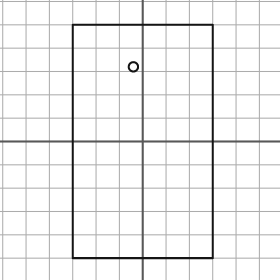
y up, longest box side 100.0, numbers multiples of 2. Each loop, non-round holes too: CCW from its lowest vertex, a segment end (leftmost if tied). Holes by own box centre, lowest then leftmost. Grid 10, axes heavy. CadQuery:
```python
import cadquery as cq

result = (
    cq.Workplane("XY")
    .moveTo(-30.0, -50.0)
    .lineTo(30.0, -50.0)
    .lineTo(30.0, 50.0)
    .lineTo(-30.0, 50.0)
    .close()
    .moveTo(-4.0, 32.0)
    .circle(2.0)
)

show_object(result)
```